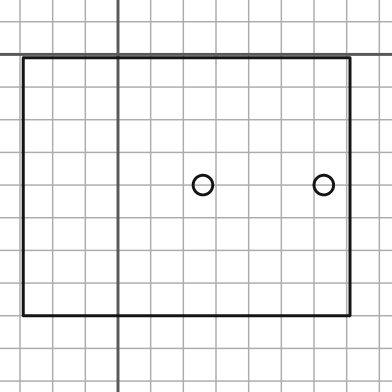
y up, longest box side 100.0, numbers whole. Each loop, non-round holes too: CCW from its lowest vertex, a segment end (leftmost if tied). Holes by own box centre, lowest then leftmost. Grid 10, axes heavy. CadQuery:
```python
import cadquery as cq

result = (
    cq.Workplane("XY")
    .moveTo(-29.0, -80.0)
    .lineTo(71.0, -80.0)
    .lineTo(71.0, -1.0)
    .lineTo(-29.0, -1.0)
    .close()
    .moveTo(26.0, -40.0)
    .circle(3.0)
    .moveTo(63.0, -40.0)
    .circle(3.0)
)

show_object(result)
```